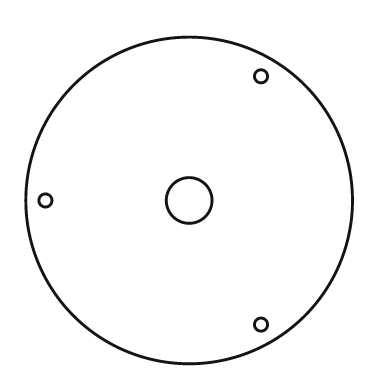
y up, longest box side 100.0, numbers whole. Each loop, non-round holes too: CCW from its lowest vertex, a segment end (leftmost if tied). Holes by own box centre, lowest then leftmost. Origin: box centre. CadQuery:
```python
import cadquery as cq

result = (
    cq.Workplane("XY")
    .moveTo(0.0, 0.0)
    .circle(50.0)
    .moveTo(22.0, -38.0)
    .circle(2.0)
    .moveTo(-44.0, 0.0)
    .circle(2.0)
    .moveTo(0.0, 0.0)
    .circle(7.0)
    .moveTo(22.0, 38.0)
    .circle(2.0)
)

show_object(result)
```